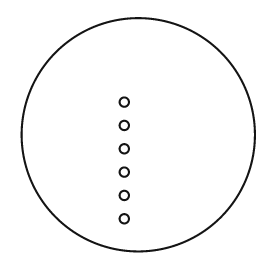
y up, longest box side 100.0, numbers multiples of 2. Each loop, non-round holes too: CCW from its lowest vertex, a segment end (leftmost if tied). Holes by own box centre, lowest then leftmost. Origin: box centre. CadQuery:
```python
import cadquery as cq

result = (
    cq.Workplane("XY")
    .moveTo(0.0, 0.0)
    .circle(50.0)
    .moveTo(-6.0, -36.0)
    .circle(2.0)
    .moveTo(-6.0, -26.0)
    .circle(2.0)
    .moveTo(-6.0, -16.0)
    .circle(2.0)
    .moveTo(-6.0, -6.0)
    .circle(2.0)
    .moveTo(-6.0, 4.0)
    .circle(2.0)
    .moveTo(-6.0, 14.0)
    .circle(2.0)
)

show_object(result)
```